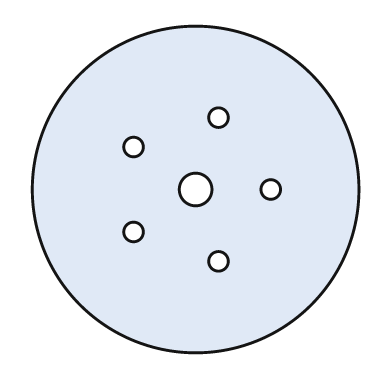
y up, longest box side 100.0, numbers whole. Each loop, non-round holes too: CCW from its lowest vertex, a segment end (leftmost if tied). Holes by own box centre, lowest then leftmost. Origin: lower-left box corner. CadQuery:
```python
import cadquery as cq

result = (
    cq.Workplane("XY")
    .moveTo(50.0, 50.0)
    .circle(50.0)
    .moveTo(57.0, 28.0)
    .circle(3.0)
    .moveTo(31.0, 37.0)
    .circle(3.0)
    .moveTo(50.0, 50.0)
    .circle(5.0)
    .moveTo(73.0, 50.0)
    .circle(3.0)
    .moveTo(31.0, 63.0)
    .circle(3.0)
    .moveTo(57.0, 72.0)
    .circle(3.0)
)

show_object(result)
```